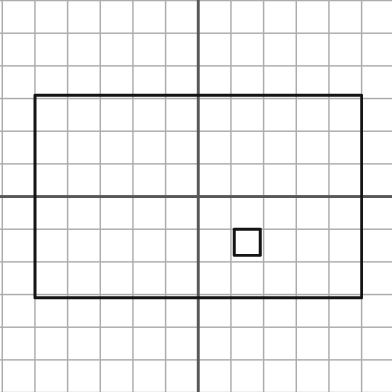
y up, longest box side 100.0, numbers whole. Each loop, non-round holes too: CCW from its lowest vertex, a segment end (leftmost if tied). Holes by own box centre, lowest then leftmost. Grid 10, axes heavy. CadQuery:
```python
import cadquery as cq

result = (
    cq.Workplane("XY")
    .moveTo(-50.0, -31.0)
    .lineTo(50.0, -31.0)
    .lineTo(50.0, 31.0)
    .lineTo(-50.0, 31.0)
    .close()
    .moveTo(11.0, -18.0)
    .lineTo(19.0, -18.0)
    .lineTo(19.0, -10.0)
    .lineTo(11.0, -10.0)
    .close()
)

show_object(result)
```